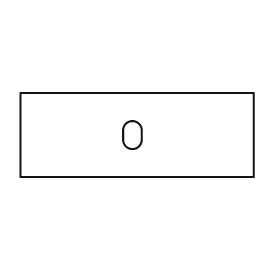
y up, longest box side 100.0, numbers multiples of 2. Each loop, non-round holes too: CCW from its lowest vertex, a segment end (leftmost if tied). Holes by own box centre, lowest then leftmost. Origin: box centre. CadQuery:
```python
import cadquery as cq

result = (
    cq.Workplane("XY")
    .moveTo(-50.0, -18.0)
    .lineTo(50.0, -18.0)
    .lineTo(50.0, 18.0)
    .lineTo(-50.0, 18.0)
    .close()
    .moveTo(-6.0, -2.0)
    .threePointArc((-2.0, -6.0), (2.0, -2.0))
    .lineTo(2.0, 2.0)
    .threePointArc((-2.0, 6.0), (-6.0, 2.0))
    .close()
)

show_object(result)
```